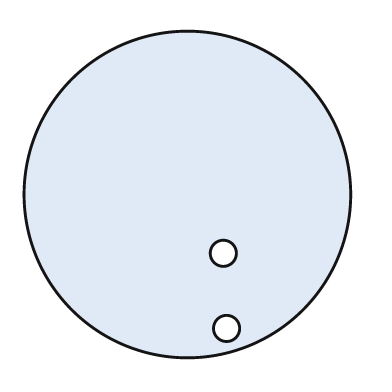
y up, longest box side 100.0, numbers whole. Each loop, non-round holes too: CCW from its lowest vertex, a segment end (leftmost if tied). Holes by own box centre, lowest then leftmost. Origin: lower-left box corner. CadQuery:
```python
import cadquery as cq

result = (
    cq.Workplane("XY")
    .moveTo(50.0, 50.0)
    .circle(50.0)
    .moveTo(62.0, 9.0)
    .circle(4.0)
    .moveTo(61.0, 32.0)
    .circle(4.0)
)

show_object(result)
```